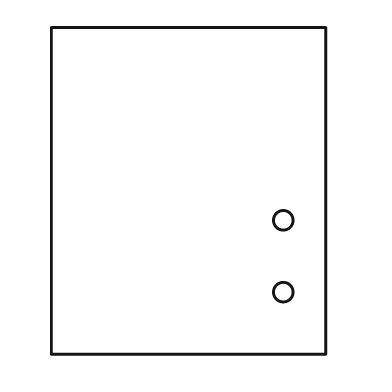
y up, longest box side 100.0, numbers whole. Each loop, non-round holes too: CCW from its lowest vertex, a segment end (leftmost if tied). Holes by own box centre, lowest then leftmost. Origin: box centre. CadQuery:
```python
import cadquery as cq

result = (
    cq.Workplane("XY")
    .moveTo(-42.0, -50.0)
    .lineTo(42.0, -50.0)
    .lineTo(42.0, 50.0)
    .lineTo(-42.0, 50.0)
    .close()
    .moveTo(29.0, -31.0)
    .circle(3.0)
    .moveTo(29.0, -9.0)
    .circle(3.0)
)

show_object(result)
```